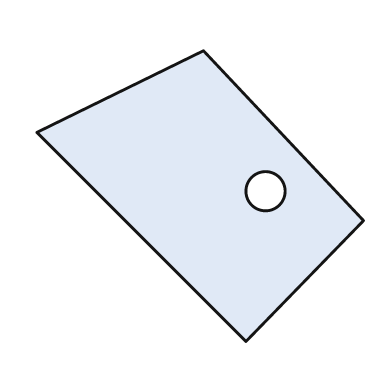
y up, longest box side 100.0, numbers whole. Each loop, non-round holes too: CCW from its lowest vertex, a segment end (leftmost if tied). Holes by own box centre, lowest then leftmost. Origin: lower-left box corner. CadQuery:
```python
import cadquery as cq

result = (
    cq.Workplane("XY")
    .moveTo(64.0, 0.0)
    .lineTo(100.0, 37.0)
    .lineTo(51.0, 89.0)
    .lineTo(0.0, 64.0)
    .close()
    .moveTo(70.0, 46.0)
    .circle(6.0)
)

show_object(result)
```